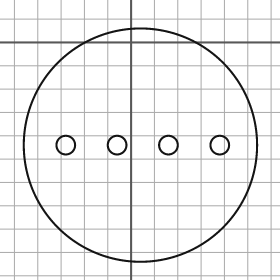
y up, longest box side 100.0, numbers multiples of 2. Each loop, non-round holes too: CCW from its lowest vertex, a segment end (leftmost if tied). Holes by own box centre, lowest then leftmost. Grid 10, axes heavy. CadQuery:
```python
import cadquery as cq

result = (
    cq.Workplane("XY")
    .moveTo(4.0, -44.0)
    .circle(50.0)
    .moveTo(-28.0, -44.0)
    .circle(4.0)
    .moveTo(-6.0, -44.0)
    .circle(4.0)
    .moveTo(16.0, -44.0)
    .circle(4.0)
    .moveTo(38.0, -44.0)
    .circle(4.0)
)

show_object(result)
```